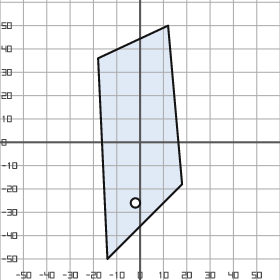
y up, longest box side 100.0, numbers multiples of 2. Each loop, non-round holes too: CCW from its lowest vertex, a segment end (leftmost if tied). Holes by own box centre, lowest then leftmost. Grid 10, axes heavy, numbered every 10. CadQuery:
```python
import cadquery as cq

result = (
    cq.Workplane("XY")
    .moveTo(-14.0, -50.0)
    .lineTo(18.0, -18.0)
    .lineTo(12.0, 50.0)
    .lineTo(-18.0, 36.0)
    .close()
    .moveTo(-2.0, -26.0)
    .circle(2.0)
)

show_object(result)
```